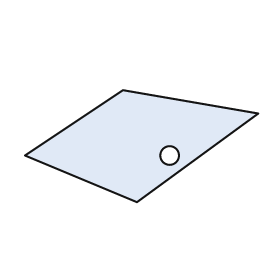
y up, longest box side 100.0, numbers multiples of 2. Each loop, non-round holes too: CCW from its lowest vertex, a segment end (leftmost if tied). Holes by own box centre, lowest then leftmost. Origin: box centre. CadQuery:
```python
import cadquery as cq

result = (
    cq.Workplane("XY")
    .moveTo(-2.0, -24.0)
    .lineTo(50.0, 14.0)
    .lineTo(-8.0, 24.0)
    .lineTo(-50.0, -4.0)
    .close()
    .moveTo(12.0, -4.0)
    .circle(4.0)
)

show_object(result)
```